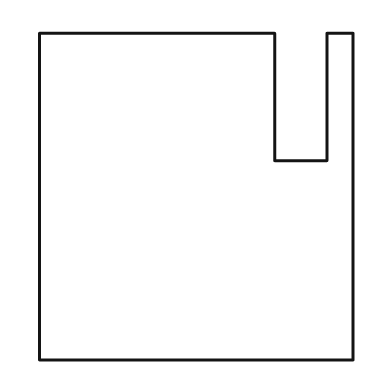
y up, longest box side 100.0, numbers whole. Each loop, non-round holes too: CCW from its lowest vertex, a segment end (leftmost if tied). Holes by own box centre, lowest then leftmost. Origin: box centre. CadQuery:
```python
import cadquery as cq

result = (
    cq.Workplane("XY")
    .moveTo(-48.0, -50.0)
    .lineTo(48.0, -50.0)
    .lineTo(48.0, 50.0)
    .lineTo(40.0, 50.0)
    .lineTo(40.0, 11.0)
    .lineTo(24.0, 11.0)
    .lineTo(24.0, 50.0)
    .lineTo(-48.0, 50.0)
    .close()
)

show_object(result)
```